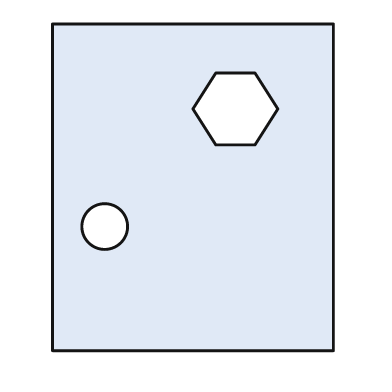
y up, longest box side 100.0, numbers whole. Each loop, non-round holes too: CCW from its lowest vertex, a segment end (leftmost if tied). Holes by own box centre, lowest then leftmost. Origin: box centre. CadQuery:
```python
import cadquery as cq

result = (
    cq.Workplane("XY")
    .moveTo(-43.0, -50.0)
    .lineTo(43.0, -50.0)
    .lineTo(43.0, 50.0)
    .lineTo(-43.0, 50.0)
    .close()
    .moveTo(-27.0, -12.0)
    .circle(7.0)
    .moveTo(7.0, 13.0)
    .lineTo(19.0, 13.0)
    .lineTo(26.0, 24.0)
    .lineTo(19.0, 35.0)
    .lineTo(7.0, 35.0)
    .lineTo(0.0, 24.0)
    .close()
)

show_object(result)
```